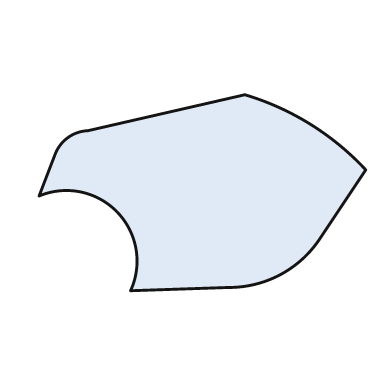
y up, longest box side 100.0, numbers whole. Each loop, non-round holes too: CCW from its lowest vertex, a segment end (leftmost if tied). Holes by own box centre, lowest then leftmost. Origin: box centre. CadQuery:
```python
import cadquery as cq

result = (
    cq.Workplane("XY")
    .moveTo(-22.0, -30.0)
    .lineTo(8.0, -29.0)
    .threePointArc((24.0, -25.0), (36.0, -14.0))
    .lineTo(50.0, 7.0)
    .threePointArc((33.0, 21.0), (13.0, 30.0))
    .lineTo(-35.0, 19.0)
    .threePointArc((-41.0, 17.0), (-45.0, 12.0))
    .lineTo(-50.0, -1.0)
    .threePointArc((-26.0, -6.0), (-22.0, -30.0))
    .close()
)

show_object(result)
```